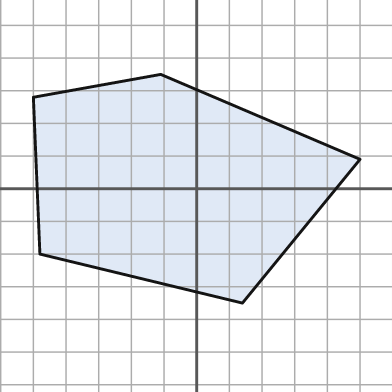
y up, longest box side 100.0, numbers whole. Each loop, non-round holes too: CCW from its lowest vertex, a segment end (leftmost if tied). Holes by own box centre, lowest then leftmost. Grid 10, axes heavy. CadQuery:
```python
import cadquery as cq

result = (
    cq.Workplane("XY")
    .moveTo(14.0, -35.0)
    .lineTo(50.0, 9.0)
    .lineTo(-11.0, 35.0)
    .lineTo(-50.0, 28.0)
    .lineTo(-48.0, -20.0)
    .close()
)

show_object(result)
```